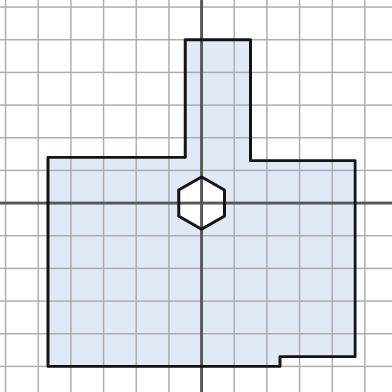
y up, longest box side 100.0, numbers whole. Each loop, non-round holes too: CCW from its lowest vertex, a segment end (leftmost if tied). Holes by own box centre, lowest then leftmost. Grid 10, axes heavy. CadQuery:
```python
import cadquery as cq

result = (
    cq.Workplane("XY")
    .moveTo(-47.0, -50.0)
    .lineTo(24.0, -50.0)
    .lineTo(24.0, -47.0)
    .lineTo(47.0, -47.0)
    .lineTo(47.0, 13.0)
    .lineTo(15.0, 13.0)
    .lineTo(15.0, 50.0)
    .lineTo(-5.0, 50.0)
    .lineTo(-5.0, 14.0)
    .lineTo(-47.0, 14.0)
    .close()
    .moveTo(0.0, -8.0)
    .lineTo(7.0, -4.0)
    .lineTo(7.0, 4.0)
    .lineTo(0.0, 8.0)
    .lineTo(-7.0, 4.0)
    .lineTo(-7.0, -4.0)
    .close()
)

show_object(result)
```